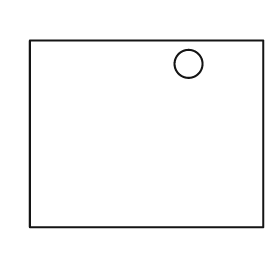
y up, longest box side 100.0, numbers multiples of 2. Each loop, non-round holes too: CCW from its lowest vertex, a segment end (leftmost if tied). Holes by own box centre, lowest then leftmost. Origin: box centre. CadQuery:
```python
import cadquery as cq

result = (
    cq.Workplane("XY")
    .moveTo(-50.0, -40.0)
    .lineTo(50.0, -40.0)
    .lineTo(50.0, 40.0)
    .lineTo(-50.0, 40.0)
    .close()
    .moveTo(18.0, 30.0)
    .circle(6.0)
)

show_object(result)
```